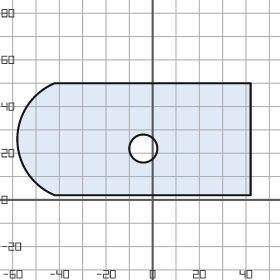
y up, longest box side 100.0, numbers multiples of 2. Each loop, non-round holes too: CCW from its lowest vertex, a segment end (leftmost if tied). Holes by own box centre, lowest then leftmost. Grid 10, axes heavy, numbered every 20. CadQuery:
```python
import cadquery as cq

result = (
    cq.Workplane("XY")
    .moveTo(-42.0, 2.0)
    .lineTo(42.0, 2.0)
    .lineTo(42.0, 50.0)
    .lineTo(-42.0, 50.0)
    .threePointArc((-58.0, 26.0), (-42.0, 2.0))
    .close()
    .moveTo(-4.0, 22.0)
    .circle(6.0)
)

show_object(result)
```